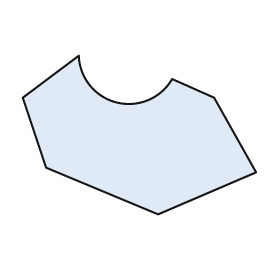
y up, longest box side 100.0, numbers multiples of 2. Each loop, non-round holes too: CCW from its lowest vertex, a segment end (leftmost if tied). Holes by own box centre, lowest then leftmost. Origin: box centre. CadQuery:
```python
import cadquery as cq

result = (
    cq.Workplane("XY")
    .moveTo(8.0, -34.0)
    .lineTo(50.0, -16.0)
    .lineTo(32.0, 16.0)
    .lineTo(14.0, 24.0)
    .threePointArc((-10.0, 14.0), (-26.0, 34.0))
    .lineTo(-50.0, 16.0)
    .lineTo(-40.0, -14.0)
    .close()
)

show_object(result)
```